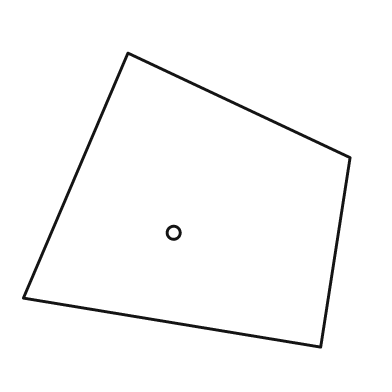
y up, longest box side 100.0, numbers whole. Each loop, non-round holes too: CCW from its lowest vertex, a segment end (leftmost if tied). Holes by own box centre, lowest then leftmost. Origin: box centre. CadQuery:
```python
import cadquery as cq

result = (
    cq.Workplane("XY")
    .moveTo(41.0, -45.0)
    .lineTo(50.0, 13.0)
    .lineTo(-18.0, 45.0)
    .lineTo(-50.0, -30.0)
    .close()
    .moveTo(-4.0, -10.0)
    .circle(2.0)
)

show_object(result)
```